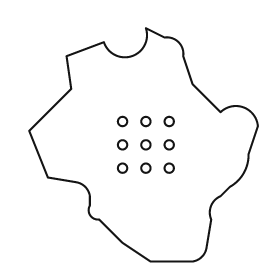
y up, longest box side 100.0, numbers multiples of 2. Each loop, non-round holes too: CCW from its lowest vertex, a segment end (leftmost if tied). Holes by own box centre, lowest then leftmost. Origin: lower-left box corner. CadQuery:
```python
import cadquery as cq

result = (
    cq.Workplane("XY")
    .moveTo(52.0, 0.0)
    .lineTo(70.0, 0.0)
    .threePointArc((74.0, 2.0), (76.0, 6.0))
    .lineTo(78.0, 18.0)
    .threePointArc((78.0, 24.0), (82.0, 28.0))
    .lineTo(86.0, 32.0)
    .threePointArc((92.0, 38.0), (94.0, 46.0))
    .lineTo(98.0, 58.0)
    .threePointArc((92.0, 66.0), (82.0, 64.0))
    .lineTo(70.0, 76.0)
    .lineTo(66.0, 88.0)
    .threePointArc((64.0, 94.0), (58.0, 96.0))
    .lineTo(50.0, 100.0)
    .threePointArc((44.0, 88.0), (32.0, 94.0))
    .lineTo(16.0, 88.0)
    .lineTo(18.0, 74.0)
    .lineTo(0.0, 56.0)
    .lineTo(8.0, 36.0)
    .lineTo(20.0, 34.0)
    .threePointArc((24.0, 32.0), (26.0, 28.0))
    .lineTo(26.0, 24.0)
    .threePointArc((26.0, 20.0), (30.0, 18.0))
    .lineTo(40.0, 8.0)
    .close()
    .moveTo(40.0, 40.0)
    .circle(2.0)
    .moveTo(50.0, 40.0)
    .circle(2.0)
    .moveTo(60.0, 40.0)
    .circle(2.0)
    .moveTo(40.0, 50.0)
    .circle(2.0)
    .moveTo(50.0, 50.0)
    .circle(2.0)
    .moveTo(60.0, 50.0)
    .circle(2.0)
    .moveTo(40.0, 60.0)
    .circle(2.0)
    .moveTo(50.0, 60.0)
    .circle(2.0)
    .moveTo(60.0, 60.0)
    .circle(2.0)
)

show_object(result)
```